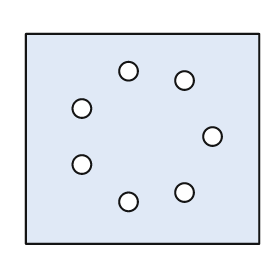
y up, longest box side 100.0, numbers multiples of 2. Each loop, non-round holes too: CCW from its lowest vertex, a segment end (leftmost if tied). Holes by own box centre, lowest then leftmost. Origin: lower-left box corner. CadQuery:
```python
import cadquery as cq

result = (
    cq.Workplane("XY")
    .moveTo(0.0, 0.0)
    .lineTo(100.0, 0.0)
    .lineTo(100.0, 90.0)
    .lineTo(0.0, 90.0)
    .close()
    .moveTo(44.0, 18.0)
    .circle(4.0)
    .moveTo(68.0, 22.0)
    .circle(4.0)
    .moveTo(24.0, 34.0)
    .circle(4.0)
    .moveTo(80.0, 46.0)
    .circle(4.0)
    .moveTo(24.0, 58.0)
    .circle(4.0)
    .moveTo(68.0, 70.0)
    .circle(4.0)
    .moveTo(44.0, 74.0)
    .circle(4.0)
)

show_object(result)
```